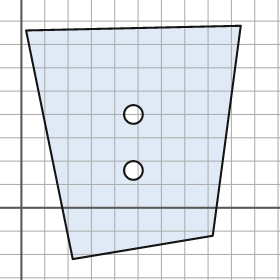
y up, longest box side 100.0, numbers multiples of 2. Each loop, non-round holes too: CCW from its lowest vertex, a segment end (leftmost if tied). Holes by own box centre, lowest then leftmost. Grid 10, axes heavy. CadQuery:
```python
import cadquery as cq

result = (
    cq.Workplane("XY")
    .moveTo(22.0, -22.0)
    .lineTo(82.0, -12.0)
    .lineTo(94.0, 78.0)
    .lineTo(2.0, 76.0)
    .close()
    .moveTo(48.0, 16.0)
    .circle(4.0)
    .moveTo(48.0, 40.0)
    .circle(4.0)
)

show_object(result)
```